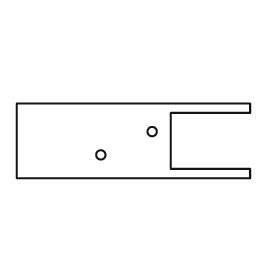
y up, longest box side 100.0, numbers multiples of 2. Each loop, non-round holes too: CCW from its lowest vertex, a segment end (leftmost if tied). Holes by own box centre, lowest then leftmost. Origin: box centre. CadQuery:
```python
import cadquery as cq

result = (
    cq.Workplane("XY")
    .moveTo(-50.0, -16.0)
    .lineTo(50.0, -16.0)
    .lineTo(50.0, -12.0)
    .lineTo(16.0, -12.0)
    .lineTo(16.0, 12.0)
    .lineTo(50.0, 12.0)
    .lineTo(50.0, 16.0)
    .lineTo(-50.0, 16.0)
    .close()
    .moveTo(-14.0, -6.0)
    .circle(2.0)
    .moveTo(8.0, 4.0)
    .circle(2.0)
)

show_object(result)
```